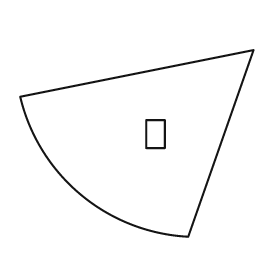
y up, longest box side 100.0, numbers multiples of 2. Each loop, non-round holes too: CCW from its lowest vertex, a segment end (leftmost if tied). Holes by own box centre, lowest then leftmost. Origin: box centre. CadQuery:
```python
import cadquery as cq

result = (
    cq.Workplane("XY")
    .moveTo(22.0, -40.0)
    .lineTo(50.0, 40.0)
    .lineTo(-50.0, 20.0)
    .threePointArc((-24.0, -22.0), (22.0, -40.0))
    .close()
    .moveTo(4.0, -2.0)
    .lineTo(12.0, -2.0)
    .lineTo(12.0, 10.0)
    .lineTo(4.0, 10.0)
    .close()
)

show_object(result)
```